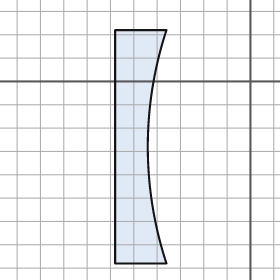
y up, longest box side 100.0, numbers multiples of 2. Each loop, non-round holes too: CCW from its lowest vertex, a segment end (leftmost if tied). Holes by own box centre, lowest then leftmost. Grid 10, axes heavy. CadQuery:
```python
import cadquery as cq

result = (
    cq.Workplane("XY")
    .moveTo(-58.0, -78.0)
    .lineTo(-36.0, -78.0)
    .threePointArc((-44.0, -28.0), (-36.0, 22.0))
    .lineTo(-58.0, 22.0)
    .close()
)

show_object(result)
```